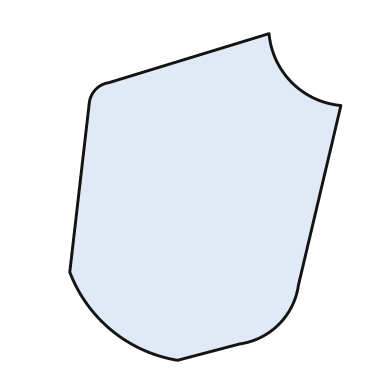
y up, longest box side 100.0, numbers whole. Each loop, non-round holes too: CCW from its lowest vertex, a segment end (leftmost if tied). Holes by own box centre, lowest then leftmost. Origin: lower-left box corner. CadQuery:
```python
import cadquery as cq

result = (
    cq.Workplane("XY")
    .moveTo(33.0, 0.0)
    .lineTo(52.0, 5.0)
    .threePointArc((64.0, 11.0), (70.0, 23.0))
    .lineTo(83.0, 78.0)
    .threePointArc((68.0, 85.0), (61.0, 100.0))
    .lineTo(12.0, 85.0)
    .threePointArc((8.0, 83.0), (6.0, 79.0))
    .lineTo(0.0, 27.0)
    .threePointArc((13.0, 9.0), (33.0, 0.0))
    .close()
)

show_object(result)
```